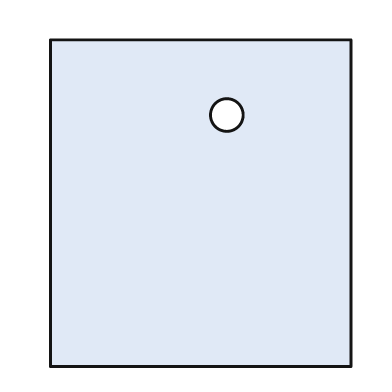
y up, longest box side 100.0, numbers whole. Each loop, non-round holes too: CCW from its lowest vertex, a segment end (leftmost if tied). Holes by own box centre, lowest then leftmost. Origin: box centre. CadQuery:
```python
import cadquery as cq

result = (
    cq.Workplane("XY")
    .moveTo(-46.0, -50.0)
    .lineTo(46.0, -50.0)
    .lineTo(46.0, 50.0)
    .lineTo(-46.0, 50.0)
    .close()
    .moveTo(8.0, 27.0)
    .circle(5.0)
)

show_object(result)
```